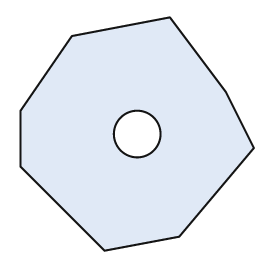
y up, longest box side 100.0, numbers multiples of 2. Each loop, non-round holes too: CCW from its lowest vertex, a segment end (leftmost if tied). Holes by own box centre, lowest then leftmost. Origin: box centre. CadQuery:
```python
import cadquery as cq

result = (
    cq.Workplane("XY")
    .moveTo(-14.0, -50.0)
    .lineTo(18.0, -44.0)
    .lineTo(50.0, -6.0)
    .lineTo(38.0, 18.0)
    .lineTo(14.0, 50.0)
    .lineTo(-28.0, 42.0)
    .lineTo(-50.0, 10.0)
    .lineTo(-50.0, -14.0)
    .close()
    .moveTo(0.0, 0.0)
    .circle(10.0)
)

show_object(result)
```